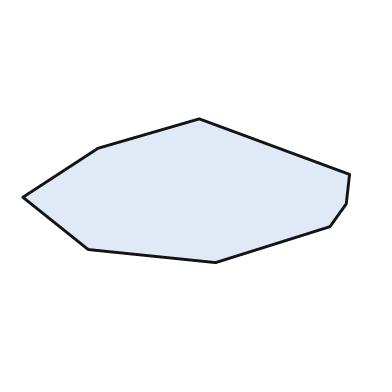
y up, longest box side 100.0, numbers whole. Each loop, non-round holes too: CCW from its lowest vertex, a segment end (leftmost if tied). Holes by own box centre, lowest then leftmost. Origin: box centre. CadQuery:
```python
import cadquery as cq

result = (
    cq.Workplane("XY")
    .moveTo(9.0, -22.0)
    .lineTo(44.0, -11.0)
    .lineTo(49.0, -4.0)
    .lineTo(50.0, 5.0)
    .lineTo(4.0, 22.0)
    .lineTo(-27.0, 13.0)
    .lineTo(-50.0, -2.0)
    .lineTo(-30.0, -18.0)
    .close()
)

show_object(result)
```